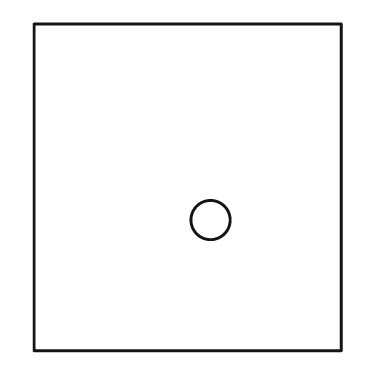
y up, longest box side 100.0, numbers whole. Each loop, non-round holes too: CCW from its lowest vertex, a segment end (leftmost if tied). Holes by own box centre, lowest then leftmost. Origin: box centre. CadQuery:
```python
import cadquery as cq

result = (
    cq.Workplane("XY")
    .moveTo(-47.0, -50.0)
    .lineTo(47.0, -50.0)
    .lineTo(47.0, 50.0)
    .lineTo(-47.0, 50.0)
    .close()
    .moveTo(7.0, -10.0)
    .circle(6.0)
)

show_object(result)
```